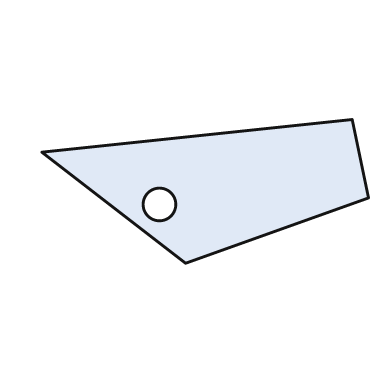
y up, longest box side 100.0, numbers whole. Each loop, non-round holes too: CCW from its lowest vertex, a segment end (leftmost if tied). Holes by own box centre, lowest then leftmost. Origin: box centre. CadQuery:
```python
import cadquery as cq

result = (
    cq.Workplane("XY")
    .moveTo(-6.0, -22.0)
    .lineTo(50.0, -2.0)
    .lineTo(45.0, 22.0)
    .lineTo(-50.0, 12.0)
    .close()
    .moveTo(-14.0, -4.0)
    .circle(5.0)
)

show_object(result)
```